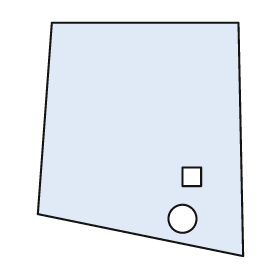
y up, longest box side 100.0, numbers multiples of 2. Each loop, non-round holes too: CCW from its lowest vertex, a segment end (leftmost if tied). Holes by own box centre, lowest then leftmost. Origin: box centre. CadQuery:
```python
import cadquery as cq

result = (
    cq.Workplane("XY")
    .moveTo(44.0, -50.0)
    .lineTo(42.0, 50.0)
    .lineTo(-38.0, 50.0)
    .lineTo(-44.0, -32.0)
    .close()
    .moveTo(18.0, -34.0)
    .circle(6.0)
    .moveTo(18.0, -20.0)
    .lineTo(26.0, -20.0)
    .lineTo(26.0, -12.0)
    .lineTo(18.0, -12.0)
    .close()
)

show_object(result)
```